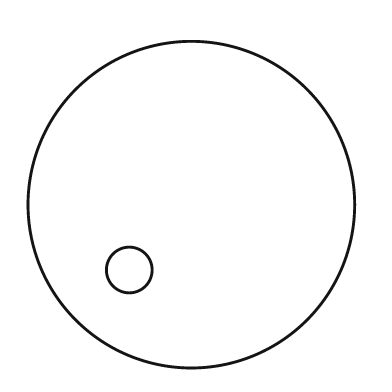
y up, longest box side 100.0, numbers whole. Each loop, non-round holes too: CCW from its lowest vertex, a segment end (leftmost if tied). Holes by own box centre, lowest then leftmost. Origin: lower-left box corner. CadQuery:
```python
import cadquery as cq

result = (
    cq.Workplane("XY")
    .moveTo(50.0, 50.0)
    .circle(50.0)
    .moveTo(31.0, 30.0)
    .circle(7.0)
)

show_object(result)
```